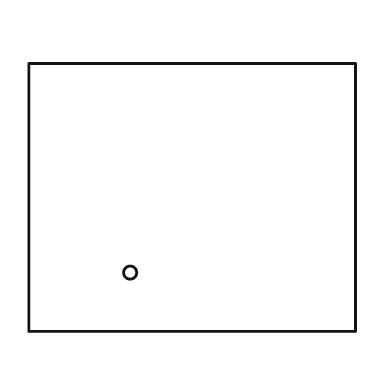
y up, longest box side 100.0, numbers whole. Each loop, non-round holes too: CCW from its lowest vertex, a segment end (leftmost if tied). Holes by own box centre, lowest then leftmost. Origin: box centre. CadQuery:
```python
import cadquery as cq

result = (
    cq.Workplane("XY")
    .moveTo(-50.0, -41.0)
    .lineTo(50.0, -41.0)
    .lineTo(50.0, 41.0)
    .lineTo(-50.0, 41.0)
    .close()
    .moveTo(-19.0, -23.0)
    .circle(2.0)
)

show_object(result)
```